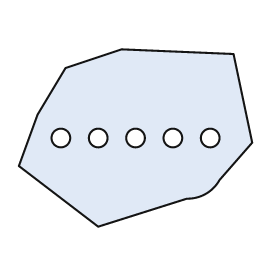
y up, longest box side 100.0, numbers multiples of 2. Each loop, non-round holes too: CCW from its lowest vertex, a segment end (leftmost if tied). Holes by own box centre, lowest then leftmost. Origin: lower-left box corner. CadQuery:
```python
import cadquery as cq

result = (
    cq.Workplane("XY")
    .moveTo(34.0, 0.0)
    .lineTo(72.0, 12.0)
    .threePointArc((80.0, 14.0), (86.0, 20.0))
    .lineTo(100.0, 36.0)
    .lineTo(92.0, 74.0)
    .lineTo(44.0, 76.0)
    .lineTo(20.0, 68.0)
    .lineTo(8.0, 48.0)
    .lineTo(0.0, 26.0)
    .close()
    .moveTo(18.0, 38.0)
    .circle(4.0)
    .moveTo(34.0, 38.0)
    .circle(4.0)
    .moveTo(50.0, 38.0)
    .circle(4.0)
    .moveTo(66.0, 38.0)
    .circle(4.0)
    .moveTo(82.0, 38.0)
    .circle(4.0)
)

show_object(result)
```